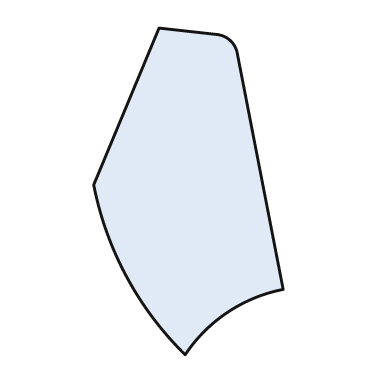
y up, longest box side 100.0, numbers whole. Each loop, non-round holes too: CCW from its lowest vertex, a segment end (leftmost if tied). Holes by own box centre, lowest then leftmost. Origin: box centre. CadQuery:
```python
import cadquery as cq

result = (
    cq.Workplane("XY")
    .moveTo(-1.0, -50.0)
    .threePointArc((12.0, -37.0), (29.0, -30.0))
    .lineTo(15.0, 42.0)
    .threePointArc((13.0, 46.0), (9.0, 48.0))
    .lineTo(-9.0, 50.0)
    .lineTo(-29.0, 2.0)
    .threePointArc((-19.0, -26.0), (-1.0, -50.0))
    .close()
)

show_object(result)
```